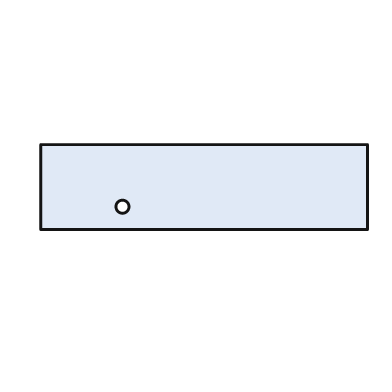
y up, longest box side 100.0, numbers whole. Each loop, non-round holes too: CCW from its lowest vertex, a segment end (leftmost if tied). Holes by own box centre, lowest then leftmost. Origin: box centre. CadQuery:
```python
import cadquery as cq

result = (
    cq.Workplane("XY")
    .moveTo(-50.0, -13.0)
    .lineTo(50.0, -13.0)
    .lineTo(50.0, 13.0)
    .lineTo(-50.0, 13.0)
    .close()
    .moveTo(-25.0, -6.0)
    .circle(2.0)
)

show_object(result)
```